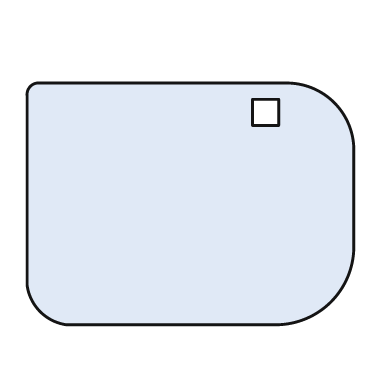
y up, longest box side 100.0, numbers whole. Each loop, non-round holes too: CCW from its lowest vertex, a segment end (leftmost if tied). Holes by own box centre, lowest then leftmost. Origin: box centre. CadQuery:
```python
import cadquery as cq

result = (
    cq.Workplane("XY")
    .moveTo(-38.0, -37.0)
    .lineTo(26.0, -37.0)
    .threePointArc((43.0, -30.0), (50.0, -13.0))
    .lineTo(50.0, 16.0)
    .threePointArc((44.0, 31.0), (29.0, 37.0))
    .lineTo(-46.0, 37.0)
    .threePointArc((-49.0, 36.0), (-50.0, 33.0))
    .lineTo(-50.0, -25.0)
    .threePointArc((-46.0, -33.0), (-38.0, -37.0))
    .close()
    .moveTo(19.0, 24.0)
    .lineTo(27.0, 24.0)
    .lineTo(27.0, 32.0)
    .lineTo(19.0, 32.0)
    .close()
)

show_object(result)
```